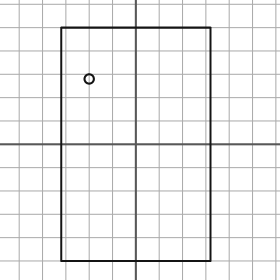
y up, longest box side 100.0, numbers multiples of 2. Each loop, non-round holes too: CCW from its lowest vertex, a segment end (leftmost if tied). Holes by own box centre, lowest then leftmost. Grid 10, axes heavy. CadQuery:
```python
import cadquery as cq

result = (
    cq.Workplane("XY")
    .moveTo(-32.0, -50.0)
    .lineTo(32.0, -50.0)
    .lineTo(32.0, 50.0)
    .lineTo(-32.0, 50.0)
    .close()
    .moveTo(-20.0, 28.0)
    .circle(2.0)
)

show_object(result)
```